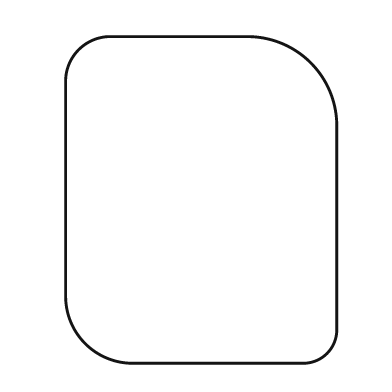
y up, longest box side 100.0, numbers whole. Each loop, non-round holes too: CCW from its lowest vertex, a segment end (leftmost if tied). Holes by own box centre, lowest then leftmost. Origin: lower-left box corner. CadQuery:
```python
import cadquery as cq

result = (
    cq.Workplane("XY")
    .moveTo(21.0, 0.0)
    .lineTo(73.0, 0.0)
    .threePointArc((80.0, 3.0), (83.0, 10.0))
    .lineTo(83.0, 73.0)
    .threePointArc((75.0, 92.0), (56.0, 100.0))
    .lineTo(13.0, 100.0)
    .threePointArc((4.0, 96.0), (0.0, 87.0))
    .lineTo(0.0, 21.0)
    .threePointArc((6.0, 6.0), (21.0, 0.0))
    .close()
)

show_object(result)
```